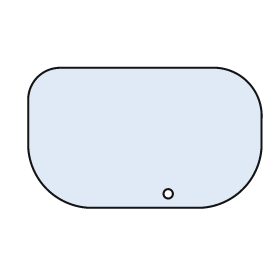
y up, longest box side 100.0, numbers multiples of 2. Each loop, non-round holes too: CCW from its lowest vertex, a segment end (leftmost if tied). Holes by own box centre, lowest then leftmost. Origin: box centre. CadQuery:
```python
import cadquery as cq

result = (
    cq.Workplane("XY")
    .moveTo(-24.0, -30.0)
    .lineTo(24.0, -30.0)
    .threePointArc((42.0, -22.0), (50.0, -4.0))
    .lineTo(50.0, 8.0)
    .threePointArc((44.0, 24.0), (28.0, 30.0))
    .lineTo(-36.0, 30.0)
    .threePointArc((-46.0, 26.0), (-50.0, 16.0))
    .lineTo(-50.0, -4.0)
    .threePointArc((-42.0, -22.0), (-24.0, -30.0))
    .close()
    .moveTo(10.0, -24.0)
    .circle(2.0)
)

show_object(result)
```